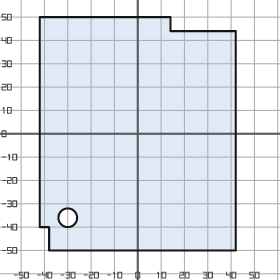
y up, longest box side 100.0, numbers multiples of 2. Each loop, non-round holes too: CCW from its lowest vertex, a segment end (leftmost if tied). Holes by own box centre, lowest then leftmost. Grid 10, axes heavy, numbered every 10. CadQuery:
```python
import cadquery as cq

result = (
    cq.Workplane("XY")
    .moveTo(-38.0, -50.0)
    .lineTo(42.0, -50.0)
    .lineTo(42.0, 44.0)
    .lineTo(14.0, 44.0)
    .lineTo(14.0, 50.0)
    .lineTo(-42.0, 50.0)
    .lineTo(-42.0, -40.0)
    .lineTo(-38.0, -40.0)
    .close()
    .moveTo(-30.0, -36.0)
    .circle(4.0)
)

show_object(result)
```